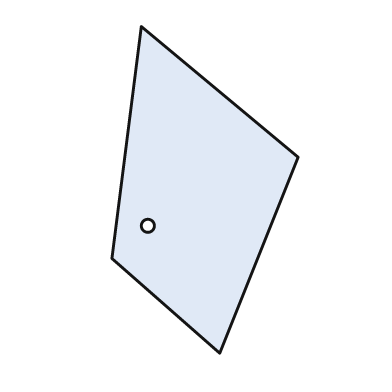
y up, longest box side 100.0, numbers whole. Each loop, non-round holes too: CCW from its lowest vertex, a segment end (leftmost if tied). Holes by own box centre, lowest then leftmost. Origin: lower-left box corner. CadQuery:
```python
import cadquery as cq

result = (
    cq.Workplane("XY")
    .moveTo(33.0, 0.0)
    .lineTo(57.0, 60.0)
    .lineTo(9.0, 100.0)
    .lineTo(0.0, 29.0)
    .close()
    .moveTo(11.0, 39.0)
    .circle(2.0)
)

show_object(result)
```